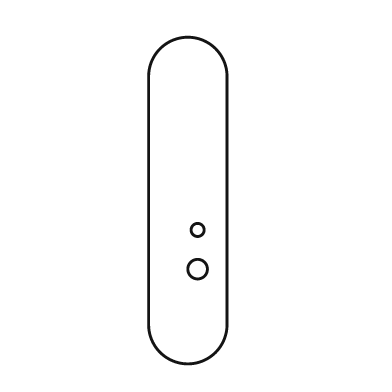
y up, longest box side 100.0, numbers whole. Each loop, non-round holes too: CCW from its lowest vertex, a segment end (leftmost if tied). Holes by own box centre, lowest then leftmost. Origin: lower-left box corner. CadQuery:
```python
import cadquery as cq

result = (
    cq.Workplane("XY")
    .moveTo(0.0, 12.0)
    .threePointArc((12.0, 0.0), (24.0, 12.0))
    .lineTo(24.0, 88.0)
    .threePointArc((12.0, 100.0), (0.0, 88.0))
    .close()
    .moveTo(15.0, 29.0)
    .circle(3.0)
    .moveTo(15.0, 41.0)
    .circle(2.0)
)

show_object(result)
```